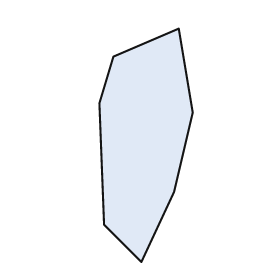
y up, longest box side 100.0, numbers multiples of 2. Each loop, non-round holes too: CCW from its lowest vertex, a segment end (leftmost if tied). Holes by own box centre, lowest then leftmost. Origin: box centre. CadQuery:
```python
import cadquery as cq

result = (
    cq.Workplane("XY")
    .moveTo(-2.0, -50.0)
    .lineTo(12.0, -20.0)
    .lineTo(20.0, 14.0)
    .lineTo(14.0, 50.0)
    .lineTo(-14.0, 38.0)
    .lineTo(-20.0, 18.0)
    .lineTo(-18.0, -34.0)
    .close()
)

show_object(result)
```